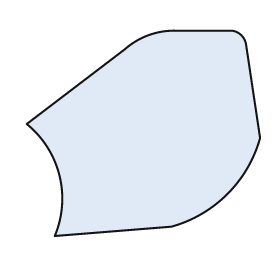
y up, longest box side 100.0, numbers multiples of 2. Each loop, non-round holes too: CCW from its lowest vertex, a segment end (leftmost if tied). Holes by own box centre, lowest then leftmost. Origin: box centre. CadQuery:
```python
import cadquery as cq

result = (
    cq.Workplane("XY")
    .moveTo(-38.0, -44.0)
    .lineTo(12.0, -40.0)
    .threePointArc((36.0, -26.0), (50.0, -2.0))
    .lineTo(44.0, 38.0)
    .threePointArc((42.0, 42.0), (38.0, 44.0))
    .lineTo(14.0, 44.0)
    .threePointArc((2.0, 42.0), (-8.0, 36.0))
    .lineTo(-50.0, 4.0)
    .threePointArc((-36.0, -18.0), (-38.0, -44.0))
    .close()
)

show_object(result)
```